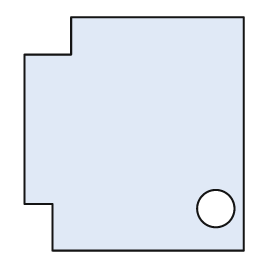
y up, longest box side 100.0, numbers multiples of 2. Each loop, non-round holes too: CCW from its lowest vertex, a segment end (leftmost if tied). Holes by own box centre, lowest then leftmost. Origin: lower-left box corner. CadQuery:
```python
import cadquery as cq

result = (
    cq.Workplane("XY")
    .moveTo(12.0, 0.0)
    .lineTo(94.0, 0.0)
    .lineTo(94.0, 100.0)
    .lineTo(20.0, 100.0)
    .lineTo(20.0, 84.0)
    .lineTo(0.0, 84.0)
    .lineTo(0.0, 20.0)
    .lineTo(12.0, 20.0)
    .close()
    .moveTo(82.0, 18.0)
    .circle(8.0)
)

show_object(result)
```